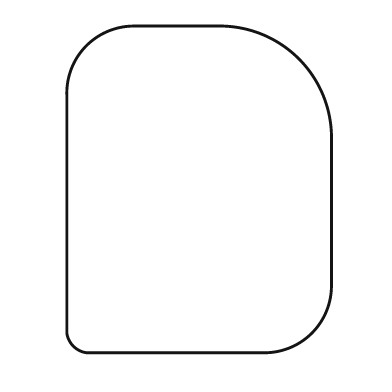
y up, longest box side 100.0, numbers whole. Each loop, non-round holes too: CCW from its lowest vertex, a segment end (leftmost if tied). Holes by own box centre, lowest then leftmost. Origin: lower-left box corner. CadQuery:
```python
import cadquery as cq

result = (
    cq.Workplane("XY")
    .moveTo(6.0, 0.0)
    .lineTo(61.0, 0.0)
    .threePointArc((75.0, 6.0), (81.0, 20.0))
    .lineTo(81.0, 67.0)
    .threePointArc((71.0, 90.0), (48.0, 100.0))
    .lineTo(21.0, 100.0)
    .threePointArc((6.0, 94.0), (0.0, 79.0))
    .lineTo(0.0, 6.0)
    .threePointArc((2.0, 2.0), (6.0, 0.0))
    .close()
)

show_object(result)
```